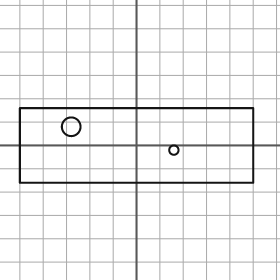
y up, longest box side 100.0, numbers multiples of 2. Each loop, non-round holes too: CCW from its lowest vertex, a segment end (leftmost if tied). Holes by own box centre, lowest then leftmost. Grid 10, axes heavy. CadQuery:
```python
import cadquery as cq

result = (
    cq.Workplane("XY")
    .moveTo(-50.0, -16.0)
    .lineTo(50.0, -16.0)
    .lineTo(50.0, 16.0)
    .lineTo(-50.0, 16.0)
    .close()
    .moveTo(16.0, -2.0)
    .circle(2.0)
    .moveTo(-28.0, 8.0)
    .circle(4.0)
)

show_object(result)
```